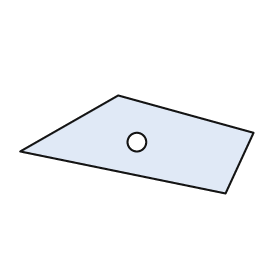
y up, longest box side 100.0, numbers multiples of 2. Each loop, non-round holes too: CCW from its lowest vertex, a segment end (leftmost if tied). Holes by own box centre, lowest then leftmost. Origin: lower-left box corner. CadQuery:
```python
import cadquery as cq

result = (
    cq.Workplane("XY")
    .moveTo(88.0, 0.0)
    .lineTo(100.0, 26.0)
    .lineTo(42.0, 42.0)
    .lineTo(0.0, 18.0)
    .close()
    .moveTo(50.0, 22.0)
    .circle(4.0)
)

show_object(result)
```